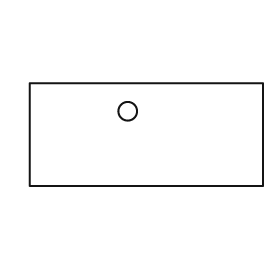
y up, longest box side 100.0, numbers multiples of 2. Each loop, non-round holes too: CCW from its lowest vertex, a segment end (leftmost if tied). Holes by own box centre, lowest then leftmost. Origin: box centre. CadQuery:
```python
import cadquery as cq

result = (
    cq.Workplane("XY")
    .moveTo(-50.0, -22.0)
    .lineTo(50.0, -22.0)
    .lineTo(50.0, 22.0)
    .lineTo(-50.0, 22.0)
    .close()
    .moveTo(-8.0, 10.0)
    .circle(4.0)
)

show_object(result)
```